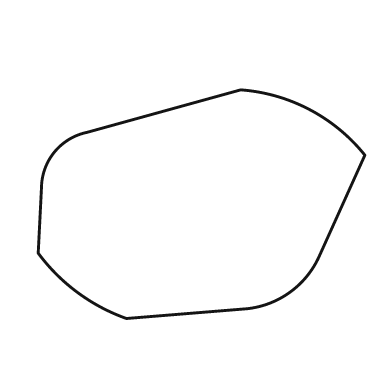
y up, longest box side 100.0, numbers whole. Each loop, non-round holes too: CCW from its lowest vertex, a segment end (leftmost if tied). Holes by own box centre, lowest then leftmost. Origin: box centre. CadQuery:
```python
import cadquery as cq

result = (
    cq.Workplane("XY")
    .moveTo(-23.0, -35.0)
    .lineTo(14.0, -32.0)
    .threePointArc((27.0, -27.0), (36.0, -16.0))
    .lineTo(50.0, 15.0)
    .threePointArc((33.0, 29.0), (12.0, 35.0))
    .lineTo(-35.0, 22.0)
    .threePointArc((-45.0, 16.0), (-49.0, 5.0))
    .lineTo(-50.0, -15.0)
    .threePointArc((-38.0, -27.0), (-23.0, -35.0))
    .close()
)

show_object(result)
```